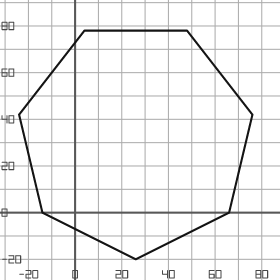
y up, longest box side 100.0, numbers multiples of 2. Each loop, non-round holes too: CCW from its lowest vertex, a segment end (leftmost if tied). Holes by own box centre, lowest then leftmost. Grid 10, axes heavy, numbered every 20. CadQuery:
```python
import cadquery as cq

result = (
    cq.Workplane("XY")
    .moveTo(26.0, -20.0)
    .lineTo(66.0, 0.0)
    .lineTo(76.0, 42.0)
    .lineTo(48.0, 78.0)
    .lineTo(4.0, 78.0)
    .lineTo(-24.0, 42.0)
    .lineTo(-14.0, 0.0)
    .close()
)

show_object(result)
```